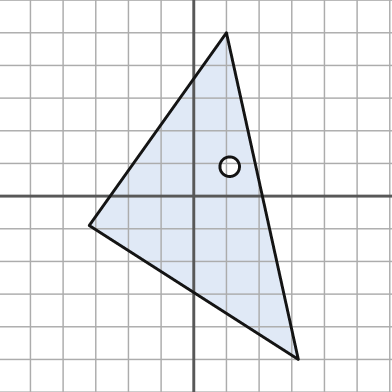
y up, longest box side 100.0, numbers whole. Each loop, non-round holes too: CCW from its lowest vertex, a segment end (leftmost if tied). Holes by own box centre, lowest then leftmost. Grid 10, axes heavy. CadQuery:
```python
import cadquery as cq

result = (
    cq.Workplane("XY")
    .moveTo(32.0, -50.0)
    .lineTo(10.0, 50.0)
    .lineTo(-32.0, -9.0)
    .close()
    .moveTo(11.0, 9.0)
    .circle(3.0)
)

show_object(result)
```